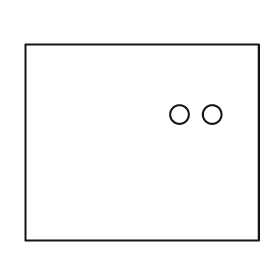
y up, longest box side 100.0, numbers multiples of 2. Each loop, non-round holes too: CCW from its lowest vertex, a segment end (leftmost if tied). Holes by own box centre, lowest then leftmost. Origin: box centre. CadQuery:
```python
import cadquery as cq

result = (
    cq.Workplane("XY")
    .moveTo(-50.0, -42.0)
    .lineTo(50.0, -42.0)
    .lineTo(50.0, 42.0)
    .lineTo(-50.0, 42.0)
    .close()
    .moveTo(16.0, 12.0)
    .circle(4.0)
    .moveTo(30.0, 12.0)
    .circle(4.0)
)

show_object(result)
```